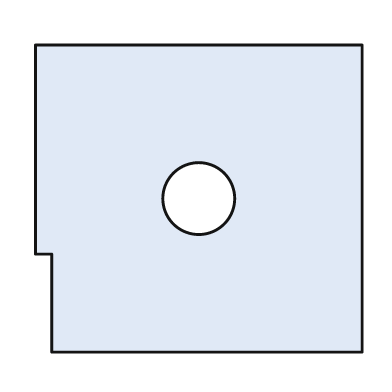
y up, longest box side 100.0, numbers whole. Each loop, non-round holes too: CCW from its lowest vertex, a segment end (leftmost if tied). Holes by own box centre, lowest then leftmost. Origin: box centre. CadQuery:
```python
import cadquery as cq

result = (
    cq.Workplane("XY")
    .moveTo(-45.0, -47.0)
    .lineTo(50.0, -47.0)
    .lineTo(50.0, 47.0)
    .lineTo(-50.0, 47.0)
    .lineTo(-50.0, -17.0)
    .lineTo(-45.0, -17.0)
    .close()
    .moveTo(0.0, 0.0)
    .circle(11.0)
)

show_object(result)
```